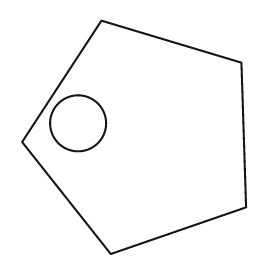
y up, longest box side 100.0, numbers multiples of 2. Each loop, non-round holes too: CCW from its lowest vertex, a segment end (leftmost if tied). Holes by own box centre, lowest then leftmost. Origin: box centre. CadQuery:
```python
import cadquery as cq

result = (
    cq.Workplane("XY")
    .moveTo(-10.0, -50.0)
    .lineTo(48.0, -30.0)
    .lineTo(46.0, 32.0)
    .lineTo(-14.0, 50.0)
    .lineTo(-48.0, -2.0)
    .close()
    .moveTo(-24.0, 6.0)
    .circle(12.0)
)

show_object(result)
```